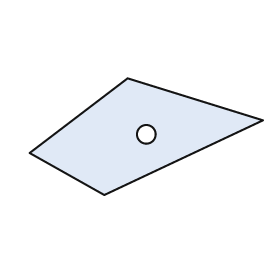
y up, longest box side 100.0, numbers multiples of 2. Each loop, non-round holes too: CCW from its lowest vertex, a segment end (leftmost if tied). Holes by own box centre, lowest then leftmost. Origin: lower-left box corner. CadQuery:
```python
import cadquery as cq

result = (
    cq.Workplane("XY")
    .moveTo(32.0, 0.0)
    .lineTo(100.0, 32.0)
    .lineTo(42.0, 50.0)
    .lineTo(0.0, 18.0)
    .close()
    .moveTo(50.0, 26.0)
    .circle(4.0)
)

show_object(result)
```